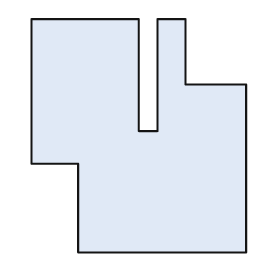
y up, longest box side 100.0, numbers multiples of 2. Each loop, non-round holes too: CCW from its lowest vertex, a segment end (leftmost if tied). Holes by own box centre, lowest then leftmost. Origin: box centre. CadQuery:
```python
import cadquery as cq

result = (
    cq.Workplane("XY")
    .moveTo(-26.0, -50.0)
    .lineTo(46.0, -50.0)
    .lineTo(46.0, 22.0)
    .lineTo(20.0, 22.0)
    .lineTo(20.0, 50.0)
    .lineTo(8.0, 50.0)
    .lineTo(8.0, 2.0)
    .lineTo(0.0, 2.0)
    .lineTo(0.0, 50.0)
    .lineTo(-46.0, 50.0)
    .lineTo(-46.0, -12.0)
    .lineTo(-26.0, -12.0)
    .close()
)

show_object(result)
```